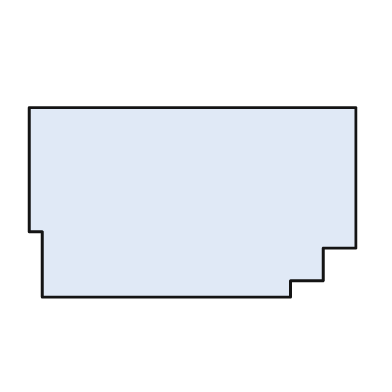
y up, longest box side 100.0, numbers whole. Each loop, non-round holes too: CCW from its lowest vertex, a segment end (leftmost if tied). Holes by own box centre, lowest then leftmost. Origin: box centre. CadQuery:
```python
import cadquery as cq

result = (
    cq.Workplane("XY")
    .moveTo(-46.0, -29.0)
    .lineTo(30.0, -29.0)
    .lineTo(30.0, -24.0)
    .lineTo(40.0, -24.0)
    .lineTo(40.0, -14.0)
    .lineTo(50.0, -14.0)
    .lineTo(50.0, 29.0)
    .lineTo(-50.0, 29.0)
    .lineTo(-50.0, -9.0)
    .lineTo(-46.0, -9.0)
    .close()
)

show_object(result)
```